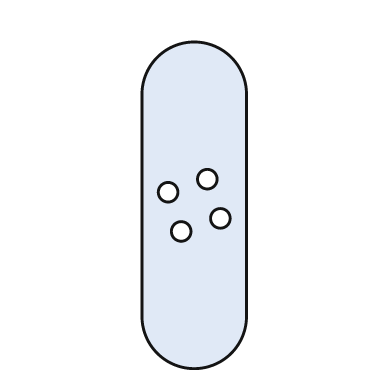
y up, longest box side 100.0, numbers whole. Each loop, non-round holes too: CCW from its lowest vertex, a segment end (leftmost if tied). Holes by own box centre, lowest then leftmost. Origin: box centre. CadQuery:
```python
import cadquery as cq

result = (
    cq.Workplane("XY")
    .moveTo(-16.0, -34.0)
    .threePointArc((0.0, -50.0), (16.0, -34.0))
    .lineTo(16.0, 34.0)
    .threePointArc((0.0, 50.0), (-16.0, 34.0))
    .close()
    .moveTo(-4.0, -8.0)
    .circle(3.0)
    .moveTo(8.0, -4.0)
    .circle(3.0)
    .moveTo(-8.0, 4.0)
    .circle(3.0)
    .moveTo(4.0, 8.0)
    .circle(3.0)
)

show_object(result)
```